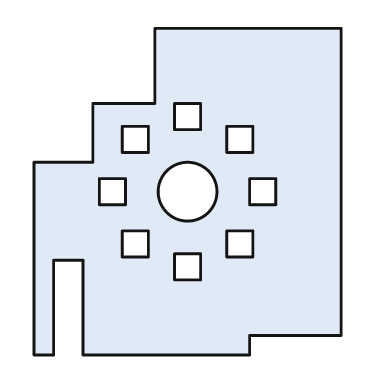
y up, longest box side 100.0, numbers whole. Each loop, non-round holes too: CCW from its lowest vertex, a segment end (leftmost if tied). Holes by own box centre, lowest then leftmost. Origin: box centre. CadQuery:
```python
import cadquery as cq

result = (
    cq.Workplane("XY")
    .moveTo(-47.0, -50.0)
    .lineTo(-41.0, -50.0)
    .lineTo(-41.0, -21.0)
    .lineTo(-32.0, -21.0)
    .lineTo(-32.0, -50.0)
    .lineTo(19.0, -50.0)
    .lineTo(19.0, -44.0)
    .lineTo(47.0, -44.0)
    .lineTo(47.0, 50.0)
    .lineTo(-10.0, 50.0)
    .lineTo(-10.0, 27.0)
    .lineTo(-29.0, 27.0)
    .lineTo(-29.0, 9.0)
    .lineTo(-47.0, 9.0)
    .close()
    .moveTo(-4.0, -27.0)
    .lineTo(4.0, -27.0)
    .lineTo(4.0, -19.0)
    .lineTo(-4.0, -19.0)
    .close()
    .moveTo(-20.0, -20.0)
    .lineTo(-12.0, -20.0)
    .lineTo(-12.0, -12.0)
    .lineTo(-20.0, -12.0)
    .close()
    .moveTo(12.0, -20.0)
    .lineTo(20.0, -20.0)
    .lineTo(20.0, -12.0)
    .lineTo(12.0, -12.0)
    .close()
    .moveTo(-27.0, -4.0)
    .lineTo(-19.0, -4.0)
    .lineTo(-19.0, 4.0)
    .lineTo(-27.0, 4.0)
    .close()
    .moveTo(0.0, 0.0)
    .circle(9.0)
    .moveTo(19.0, -4.0)
    .lineTo(27.0, -4.0)
    .lineTo(27.0, 4.0)
    .lineTo(19.0, 4.0)
    .close()
    .moveTo(-20.0, 12.0)
    .lineTo(-12.0, 12.0)
    .lineTo(-12.0, 20.0)
    .lineTo(-20.0, 20.0)
    .close()
    .moveTo(12.0, 12.0)
    .lineTo(20.0, 12.0)
    .lineTo(20.0, 20.0)
    .lineTo(12.0, 20.0)
    .close()
    .moveTo(-4.0, 19.0)
    .lineTo(4.0, 19.0)
    .lineTo(4.0, 27.0)
    .lineTo(-4.0, 27.0)
    .close()
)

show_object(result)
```